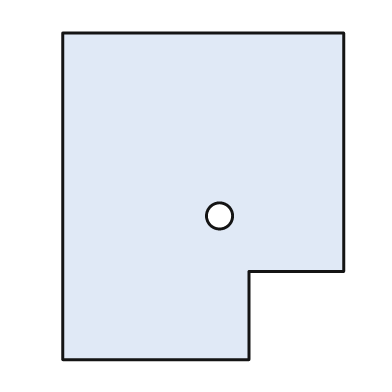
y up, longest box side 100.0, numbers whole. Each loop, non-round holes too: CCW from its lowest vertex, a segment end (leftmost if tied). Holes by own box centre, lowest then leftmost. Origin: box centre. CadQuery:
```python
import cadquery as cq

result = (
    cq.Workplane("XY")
    .moveTo(-43.0, -50.0)
    .lineTo(14.0, -50.0)
    .lineTo(14.0, -23.0)
    .lineTo(43.0, -23.0)
    .lineTo(43.0, 50.0)
    .lineTo(-43.0, 50.0)
    .close()
    .moveTo(5.0, -6.0)
    .circle(4.0)
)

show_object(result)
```